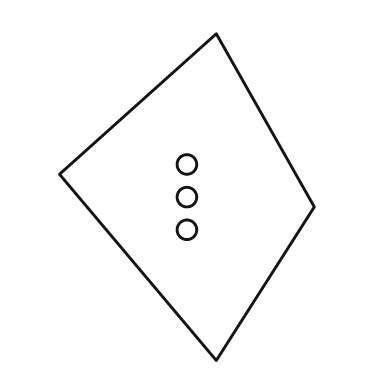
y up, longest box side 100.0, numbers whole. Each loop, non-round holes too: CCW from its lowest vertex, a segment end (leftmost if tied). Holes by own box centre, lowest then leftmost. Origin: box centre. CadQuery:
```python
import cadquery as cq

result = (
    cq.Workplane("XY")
    .moveTo(9.0, -50.0)
    .lineTo(39.0, -3.0)
    .lineTo(9.0, 50.0)
    .lineTo(-39.0, 7.0)
    .close()
    .moveTo(0.0, -10.0)
    .circle(3.0)
    .moveTo(0.0, 0.0)
    .circle(3.0)
    .moveTo(0.0, 10.0)
    .circle(3.0)
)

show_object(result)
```